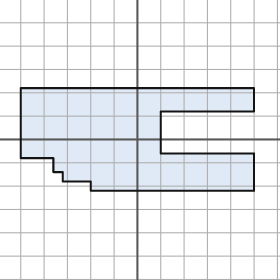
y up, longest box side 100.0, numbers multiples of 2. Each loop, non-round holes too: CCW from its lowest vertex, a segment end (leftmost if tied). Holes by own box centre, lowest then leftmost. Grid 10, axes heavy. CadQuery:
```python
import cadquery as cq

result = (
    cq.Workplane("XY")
    .moveTo(-20.0, -22.0)
    .lineTo(50.0, -22.0)
    .lineTo(50.0, -6.0)
    .lineTo(10.0, -6.0)
    .lineTo(10.0, 12.0)
    .lineTo(50.0, 12.0)
    .lineTo(50.0, 22.0)
    .lineTo(-50.0, 22.0)
    .lineTo(-50.0, -8.0)
    .lineTo(-36.0, -8.0)
    .lineTo(-36.0, -14.0)
    .lineTo(-32.0, -14.0)
    .lineTo(-32.0, -18.0)
    .lineTo(-20.0, -18.0)
    .close()
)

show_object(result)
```